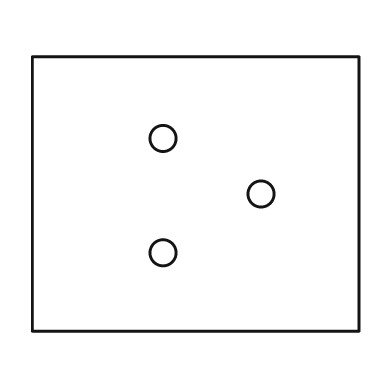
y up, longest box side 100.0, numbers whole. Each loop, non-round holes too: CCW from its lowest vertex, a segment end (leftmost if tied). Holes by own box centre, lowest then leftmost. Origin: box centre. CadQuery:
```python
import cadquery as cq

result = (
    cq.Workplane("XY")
    .moveTo(-50.0, -42.0)
    .lineTo(50.0, -42.0)
    .lineTo(50.0, 42.0)
    .lineTo(-50.0, 42.0)
    .close()
    .moveTo(-10.0, -18.0)
    .circle(4.0)
    .moveTo(20.0, 0.0)
    .circle(4.0)
    .moveTo(-10.0, 17.0)
    .circle(4.0)
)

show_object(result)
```